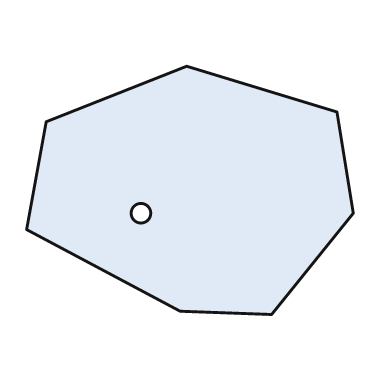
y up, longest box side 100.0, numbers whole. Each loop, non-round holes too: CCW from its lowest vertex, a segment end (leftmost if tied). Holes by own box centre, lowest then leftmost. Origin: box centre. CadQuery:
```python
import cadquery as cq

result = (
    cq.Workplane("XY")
    .moveTo(25.0, -38.0)
    .lineTo(50.0, -7.0)
    .lineTo(45.0, 24.0)
    .lineTo(-1.0, 38.0)
    .lineTo(-44.0, 21.0)
    .lineTo(-50.0, -12.0)
    .lineTo(-3.0, -37.0)
    .close()
    .moveTo(-15.0, -7.0)
    .circle(3.0)
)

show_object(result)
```